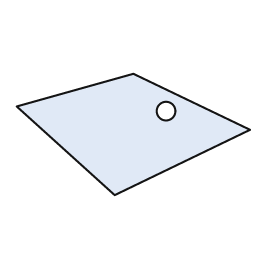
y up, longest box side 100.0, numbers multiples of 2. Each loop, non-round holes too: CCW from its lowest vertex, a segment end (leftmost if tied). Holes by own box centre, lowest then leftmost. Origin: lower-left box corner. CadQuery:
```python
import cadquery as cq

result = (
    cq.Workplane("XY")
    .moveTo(42.0, 0.0)
    .lineTo(100.0, 28.0)
    .lineTo(50.0, 52.0)
    .lineTo(0.0, 38.0)
    .close()
    .moveTo(64.0, 36.0)
    .circle(4.0)
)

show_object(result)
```